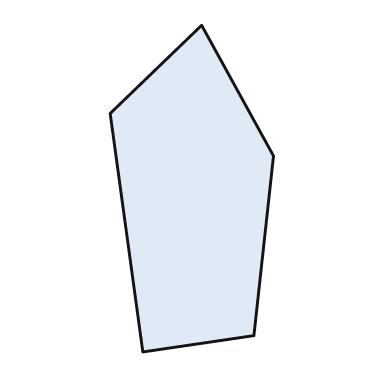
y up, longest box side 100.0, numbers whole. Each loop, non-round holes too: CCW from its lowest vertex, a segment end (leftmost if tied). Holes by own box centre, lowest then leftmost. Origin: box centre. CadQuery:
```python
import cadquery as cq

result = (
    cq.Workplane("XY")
    .moveTo(-15.0, -50.0)
    .lineTo(19.0, -45.0)
    .lineTo(25.0, 10.0)
    .lineTo(3.0, 50.0)
    .lineTo(-25.0, 23.0)
    .close()
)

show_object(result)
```